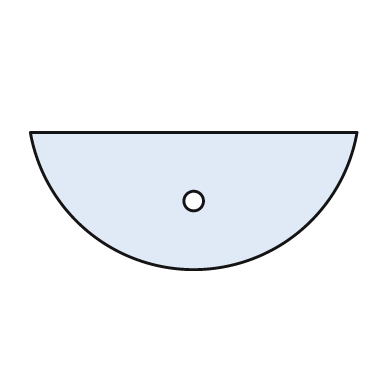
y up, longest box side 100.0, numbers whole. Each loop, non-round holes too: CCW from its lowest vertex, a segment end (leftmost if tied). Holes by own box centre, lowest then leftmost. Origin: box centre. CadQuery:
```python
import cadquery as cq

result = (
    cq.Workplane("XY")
    .moveTo(-50.0, 21.0)
    .threePointArc((0.0, -21.0), (50.0, 21.0))
    .close()
    .moveTo(0.0, 0.0)
    .circle(3.0)
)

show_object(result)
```